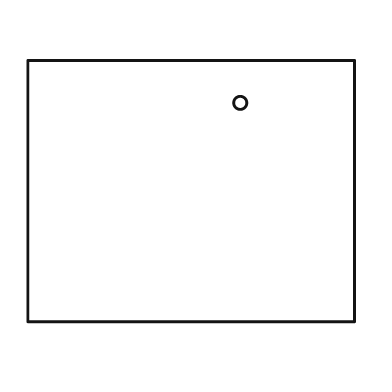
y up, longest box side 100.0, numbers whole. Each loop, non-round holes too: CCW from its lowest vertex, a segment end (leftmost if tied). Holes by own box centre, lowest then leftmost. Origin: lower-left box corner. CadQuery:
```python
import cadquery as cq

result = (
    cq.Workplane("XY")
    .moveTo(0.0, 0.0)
    .lineTo(100.0, 0.0)
    .lineTo(100.0, 80.0)
    .lineTo(0.0, 80.0)
    .close()
    .moveTo(65.0, 67.0)
    .circle(2.0)
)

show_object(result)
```